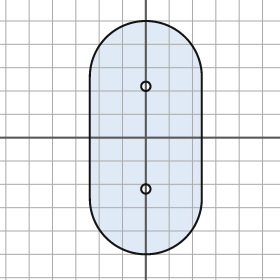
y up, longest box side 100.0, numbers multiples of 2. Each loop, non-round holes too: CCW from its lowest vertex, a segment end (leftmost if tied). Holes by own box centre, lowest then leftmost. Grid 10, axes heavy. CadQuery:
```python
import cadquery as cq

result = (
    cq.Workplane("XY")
    .moveTo(-24.0, -26.0)
    .threePointArc((0.0, -50.0), (24.0, -26.0))
    .lineTo(24.0, 26.0)
    .threePointArc((0.0, 50.0), (-24.0, 26.0))
    .close()
    .moveTo(0.0, -22.0)
    .circle(2.0)
    .moveTo(0.0, 22.0)
    .circle(2.0)
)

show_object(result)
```